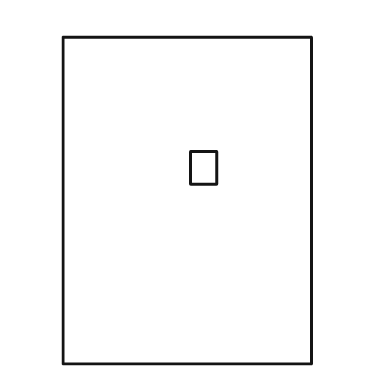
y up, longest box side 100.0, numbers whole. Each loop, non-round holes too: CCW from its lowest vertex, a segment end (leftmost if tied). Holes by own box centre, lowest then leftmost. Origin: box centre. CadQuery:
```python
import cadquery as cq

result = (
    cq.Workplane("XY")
    .moveTo(-38.0, -50.0)
    .lineTo(38.0, -50.0)
    .lineTo(38.0, 50.0)
    .lineTo(-38.0, 50.0)
    .close()
    .moveTo(1.0, 5.0)
    .lineTo(9.0, 5.0)
    .lineTo(9.0, 15.0)
    .lineTo(1.0, 15.0)
    .close()
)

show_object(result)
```